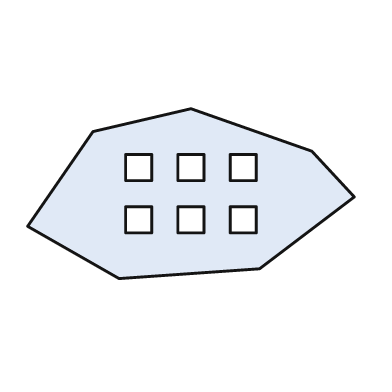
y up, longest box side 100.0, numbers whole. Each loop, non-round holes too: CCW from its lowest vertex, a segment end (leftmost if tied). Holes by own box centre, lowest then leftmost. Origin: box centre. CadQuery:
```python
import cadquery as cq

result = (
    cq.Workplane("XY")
    .moveTo(-22.0, -26.0)
    .lineTo(21.0, -23.0)
    .lineTo(50.0, -1.0)
    .lineTo(37.0, 13.0)
    .lineTo(0.0, 26.0)
    .lineTo(-30.0, 19.0)
    .lineTo(-50.0, -10.0)
    .close()
    .moveTo(-20.0, -12.0)
    .lineTo(-12.0, -12.0)
    .lineTo(-12.0, -4.0)
    .lineTo(-20.0, -4.0)
    .close()
    .moveTo(-4.0, -12.0)
    .lineTo(4.0, -12.0)
    .lineTo(4.0, -4.0)
    .lineTo(-4.0, -4.0)
    .close()
    .moveTo(12.0, -12.0)
    .lineTo(20.0, -12.0)
    .lineTo(20.0, -4.0)
    .lineTo(12.0, -4.0)
    .close()
    .moveTo(-20.0, 4.0)
    .lineTo(-12.0, 4.0)
    .lineTo(-12.0, 12.0)
    .lineTo(-20.0, 12.0)
    .close()
    .moveTo(-4.0, 4.0)
    .lineTo(4.0, 4.0)
    .lineTo(4.0, 12.0)
    .lineTo(-4.0, 12.0)
    .close()
    .moveTo(12.0, 4.0)
    .lineTo(20.0, 4.0)
    .lineTo(20.0, 12.0)
    .lineTo(12.0, 12.0)
    .close()
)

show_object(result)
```